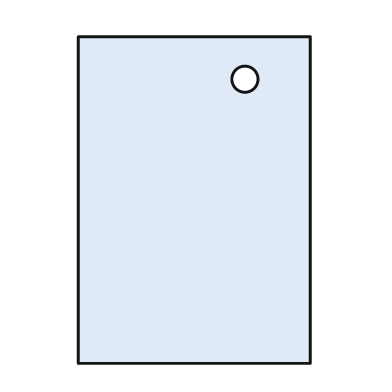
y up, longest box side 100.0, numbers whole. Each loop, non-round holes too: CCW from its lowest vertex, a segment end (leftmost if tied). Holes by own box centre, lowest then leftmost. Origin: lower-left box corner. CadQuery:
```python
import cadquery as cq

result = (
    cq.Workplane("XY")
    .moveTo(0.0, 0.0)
    .lineTo(71.0, 0.0)
    .lineTo(71.0, 100.0)
    .lineTo(0.0, 100.0)
    .close()
    .moveTo(51.0, 87.0)
    .circle(4.0)
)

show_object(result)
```